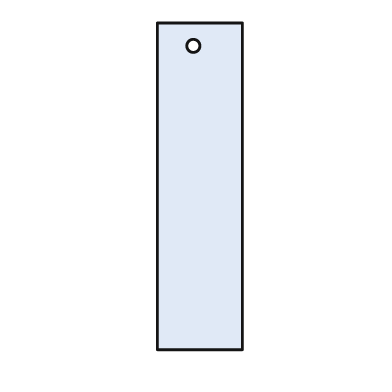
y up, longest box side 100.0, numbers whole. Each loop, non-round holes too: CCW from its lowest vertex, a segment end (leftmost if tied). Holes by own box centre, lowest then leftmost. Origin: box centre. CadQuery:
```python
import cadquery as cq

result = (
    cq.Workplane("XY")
    .moveTo(-13.0, -50.0)
    .lineTo(13.0, -50.0)
    .lineTo(13.0, 50.0)
    .lineTo(-13.0, 50.0)
    .close()
    .moveTo(-2.0, 43.0)
    .circle(2.0)
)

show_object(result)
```